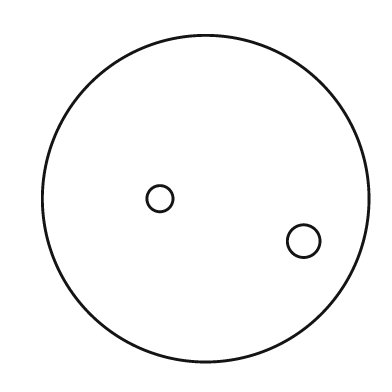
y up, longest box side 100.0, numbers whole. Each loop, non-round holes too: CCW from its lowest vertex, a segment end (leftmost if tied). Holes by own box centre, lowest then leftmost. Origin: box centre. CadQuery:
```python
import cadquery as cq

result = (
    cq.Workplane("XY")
    .moveTo(0.0, 0.0)
    .circle(50.0)
    .moveTo(30.0, -13.0)
    .circle(5.0)
    .moveTo(-14.0, 0.0)
    .circle(4.0)
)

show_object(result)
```